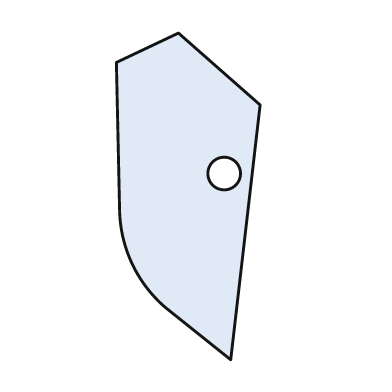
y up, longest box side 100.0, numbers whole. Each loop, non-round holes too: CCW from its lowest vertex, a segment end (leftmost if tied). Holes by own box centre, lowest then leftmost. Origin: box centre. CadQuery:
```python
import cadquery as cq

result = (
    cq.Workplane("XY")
    .moveTo(13.0, -50.0)
    .lineTo(22.0, 28.0)
    .lineTo(-3.0, 50.0)
    .lineTo(-22.0, 41.0)
    .lineTo(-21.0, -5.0)
    .threePointArc((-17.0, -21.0), (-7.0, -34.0))
    .close()
    .moveTo(11.0, 7.0)
    .circle(5.0)
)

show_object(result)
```